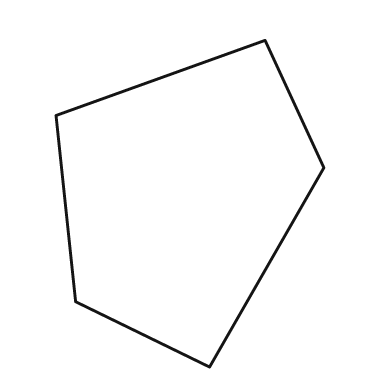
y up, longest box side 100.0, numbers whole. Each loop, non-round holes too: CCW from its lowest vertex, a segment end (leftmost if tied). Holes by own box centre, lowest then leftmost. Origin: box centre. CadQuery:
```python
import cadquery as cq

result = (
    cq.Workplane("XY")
    .moveTo(6.0, -50.0)
    .lineTo(41.0, 11.0)
    .lineTo(23.0, 50.0)
    .lineTo(-41.0, 27.0)
    .lineTo(-35.0, -30.0)
    .close()
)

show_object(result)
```